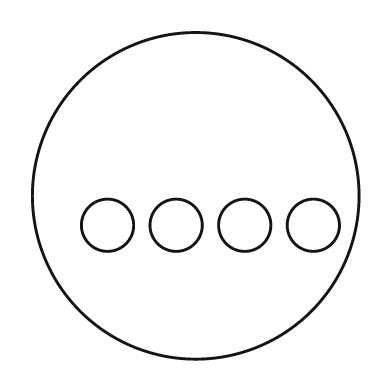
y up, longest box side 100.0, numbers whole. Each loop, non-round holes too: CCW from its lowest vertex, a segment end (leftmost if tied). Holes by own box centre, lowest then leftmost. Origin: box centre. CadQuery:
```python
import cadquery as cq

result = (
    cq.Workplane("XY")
    .moveTo(0.0, 0.0)
    .circle(50.0)
    .moveTo(-27.0, -9.0)
    .circle(8.0)
    .moveTo(-6.0, -9.0)
    .circle(8.0)
    .moveTo(15.0, -9.0)
    .circle(8.0)
    .moveTo(36.0, -9.0)
    .circle(8.0)
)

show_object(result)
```